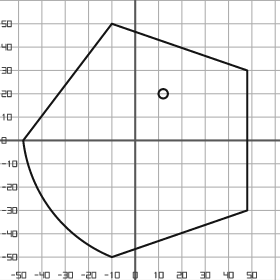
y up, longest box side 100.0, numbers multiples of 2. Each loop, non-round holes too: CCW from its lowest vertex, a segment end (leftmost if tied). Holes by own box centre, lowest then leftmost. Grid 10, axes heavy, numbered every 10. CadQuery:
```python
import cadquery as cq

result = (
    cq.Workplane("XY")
    .moveTo(-10.0, -50.0)
    .lineTo(48.0, -30.0)
    .lineTo(48.0, 30.0)
    .lineTo(-10.0, 50.0)
    .lineTo(-48.0, 0.0)
    .threePointArc((-36.0, -30.0), (-10.0, -50.0))
    .close()
    .moveTo(12.0, 20.0)
    .circle(2.0)
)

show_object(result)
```